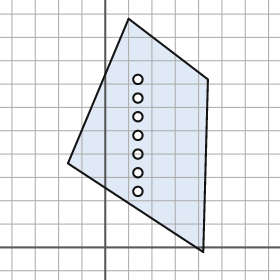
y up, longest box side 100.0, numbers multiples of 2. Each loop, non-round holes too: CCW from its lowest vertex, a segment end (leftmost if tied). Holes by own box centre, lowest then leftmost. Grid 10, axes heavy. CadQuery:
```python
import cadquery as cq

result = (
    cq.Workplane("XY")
    .moveTo(42.0, -2.0)
    .lineTo(44.0, 72.0)
    .lineTo(10.0, 98.0)
    .lineTo(-16.0, 36.0)
    .close()
    .moveTo(14.0, 24.0)
    .circle(2.0)
    .moveTo(14.0, 32.0)
    .circle(2.0)
    .moveTo(14.0, 40.0)
    .circle(2.0)
    .moveTo(14.0, 48.0)
    .circle(2.0)
    .moveTo(14.0, 56.0)
    .circle(2.0)
    .moveTo(14.0, 64.0)
    .circle(2.0)
    .moveTo(14.0, 72.0)
    .circle(2.0)
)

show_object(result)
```